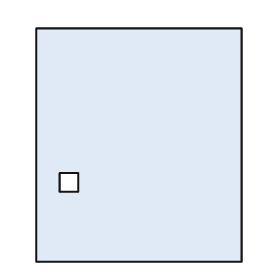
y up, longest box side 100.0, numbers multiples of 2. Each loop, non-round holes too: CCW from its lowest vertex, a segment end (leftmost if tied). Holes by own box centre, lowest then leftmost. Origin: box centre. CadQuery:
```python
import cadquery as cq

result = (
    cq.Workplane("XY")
    .moveTo(-44.0, -50.0)
    .lineTo(44.0, -50.0)
    .lineTo(44.0, 50.0)
    .lineTo(-44.0, 50.0)
    .close()
    .moveTo(-34.0, -20.0)
    .lineTo(-26.0, -20.0)
    .lineTo(-26.0, -12.0)
    .lineTo(-34.0, -12.0)
    .close()
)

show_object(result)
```